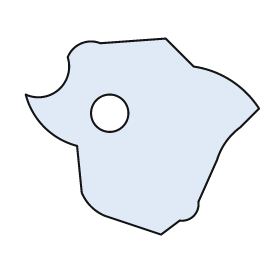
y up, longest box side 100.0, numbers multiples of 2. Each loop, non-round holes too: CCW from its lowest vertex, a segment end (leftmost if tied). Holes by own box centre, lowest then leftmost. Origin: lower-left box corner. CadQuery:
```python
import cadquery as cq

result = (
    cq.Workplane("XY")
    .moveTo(58.0, 0.0)
    .lineTo(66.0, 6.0)
    .threePointArc((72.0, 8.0), (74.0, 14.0))
    .lineTo(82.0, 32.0)
    .threePointArc((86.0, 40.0), (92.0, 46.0))
    .lineTo(100.0, 54.0)
    .threePointArc((88.0, 66.0), (72.0, 72.0))
    .lineTo(60.0, 84.0)
    .lineTo(32.0, 82.0)
    .threePointArc((24.0, 82.0), (18.0, 76.0))
    .threePointArc((14.0, 62.0), (0.0, 60.0))
    .threePointArc((8.0, 46.0), (22.0, 38.0))
    .lineTo(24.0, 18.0)
    .threePointArc((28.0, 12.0), (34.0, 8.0))
    .close()
    .moveTo(36.0, 52.0)
    .circle(8.0)
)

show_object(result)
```